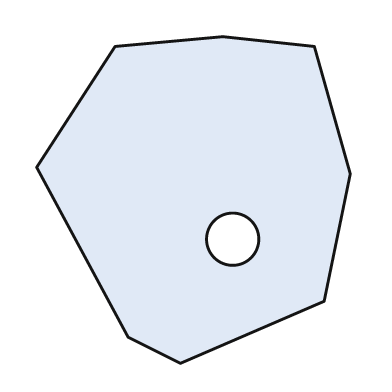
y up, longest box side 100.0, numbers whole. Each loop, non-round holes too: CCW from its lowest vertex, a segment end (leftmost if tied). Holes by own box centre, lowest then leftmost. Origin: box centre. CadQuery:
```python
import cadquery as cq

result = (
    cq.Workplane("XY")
    .moveTo(-4.0, -50.0)
    .lineTo(40.0, -31.0)
    .lineTo(48.0, 8.0)
    .lineTo(37.0, 47.0)
    .lineTo(9.0, 50.0)
    .lineTo(-24.0, 47.0)
    .lineTo(-48.0, 10.0)
    .lineTo(-20.0, -42.0)
    .close()
    .moveTo(12.0, -12.0)
    .circle(8.0)
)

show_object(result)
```